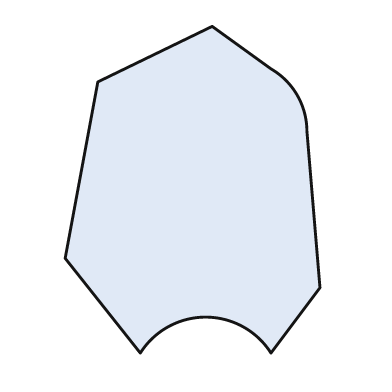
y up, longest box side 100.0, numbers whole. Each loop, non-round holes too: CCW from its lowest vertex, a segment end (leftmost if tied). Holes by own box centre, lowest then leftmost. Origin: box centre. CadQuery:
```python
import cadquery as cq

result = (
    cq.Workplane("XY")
    .moveTo(-16.0, -50.0)
    .threePointArc((4.0, -39.0), (24.0, -50.0))
    .lineTo(39.0, -30.0)
    .lineTo(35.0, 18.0)
    .threePointArc((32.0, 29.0), (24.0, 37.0))
    .lineTo(6.0, 50.0)
    .lineTo(-29.0, 33.0)
    .lineTo(-39.0, -21.0)
    .close()
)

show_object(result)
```